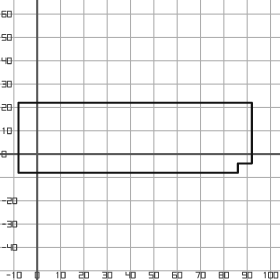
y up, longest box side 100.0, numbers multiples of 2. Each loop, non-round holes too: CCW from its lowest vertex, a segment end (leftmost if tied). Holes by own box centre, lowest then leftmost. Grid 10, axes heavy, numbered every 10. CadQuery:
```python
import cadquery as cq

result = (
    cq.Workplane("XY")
    .moveTo(-8.0, -8.0)
    .lineTo(86.0, -8.0)
    .lineTo(86.0, -4.0)
    .lineTo(92.0, -4.0)
    .lineTo(92.0, 22.0)
    .lineTo(-8.0, 22.0)
    .close()
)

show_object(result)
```